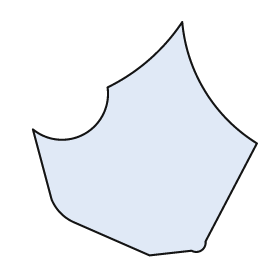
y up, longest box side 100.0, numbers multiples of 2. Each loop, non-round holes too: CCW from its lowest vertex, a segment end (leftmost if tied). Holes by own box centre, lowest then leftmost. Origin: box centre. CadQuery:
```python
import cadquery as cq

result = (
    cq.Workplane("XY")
    .moveTo(2.0, -50.0)
    .lineTo(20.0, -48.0)
    .threePointArc((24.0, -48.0), (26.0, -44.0))
    .lineTo(48.0, -2.0)
    .threePointArc((26.0, 20.0), (16.0, 50.0))
    .threePointArc((2.0, 34.0), (-16.0, 22.0))
    .threePointArc((-26.0, 2.0), (-48.0, 4.0))
    .lineTo(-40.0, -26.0)
    .threePointArc((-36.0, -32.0), (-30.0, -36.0))
    .close()
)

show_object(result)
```